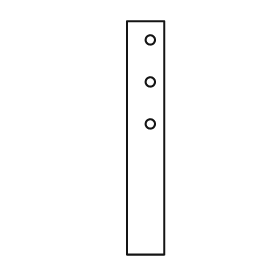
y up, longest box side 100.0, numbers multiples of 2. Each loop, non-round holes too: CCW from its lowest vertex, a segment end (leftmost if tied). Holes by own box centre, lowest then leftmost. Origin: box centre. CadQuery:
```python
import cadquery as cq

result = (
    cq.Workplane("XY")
    .moveTo(-8.0, -50.0)
    .lineTo(8.0, -50.0)
    .lineTo(8.0, 50.0)
    .lineTo(-8.0, 50.0)
    .close()
    .moveTo(2.0, 6.0)
    .circle(2.0)
    .moveTo(2.0, 24.0)
    .circle(2.0)
    .moveTo(2.0, 42.0)
    .circle(2.0)
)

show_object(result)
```